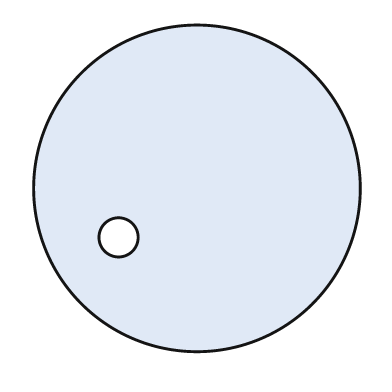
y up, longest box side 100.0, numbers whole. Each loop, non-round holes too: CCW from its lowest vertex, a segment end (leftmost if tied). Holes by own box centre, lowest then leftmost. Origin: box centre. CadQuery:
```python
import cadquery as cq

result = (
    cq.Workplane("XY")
    .moveTo(0.0, 0.0)
    .circle(50.0)
    .moveTo(-24.0, -15.0)
    .circle(6.0)
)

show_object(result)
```